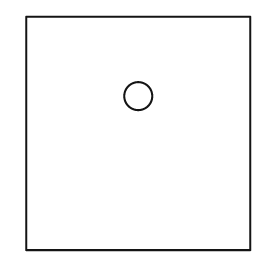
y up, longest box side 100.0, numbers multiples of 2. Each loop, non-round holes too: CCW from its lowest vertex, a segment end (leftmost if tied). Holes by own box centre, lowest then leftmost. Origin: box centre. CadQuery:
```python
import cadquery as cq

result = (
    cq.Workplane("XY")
    .moveTo(-48.0, -50.0)
    .lineTo(48.0, -50.0)
    .lineTo(48.0, 50.0)
    .lineTo(-48.0, 50.0)
    .close()
    .moveTo(0.0, 16.0)
    .circle(6.0)
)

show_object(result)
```